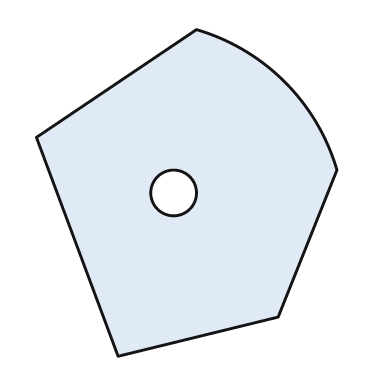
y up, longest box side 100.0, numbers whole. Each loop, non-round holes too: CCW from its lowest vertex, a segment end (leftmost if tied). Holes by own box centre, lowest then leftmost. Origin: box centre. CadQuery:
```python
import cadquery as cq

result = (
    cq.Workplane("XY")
    .moveTo(-21.0, -50.0)
    .lineTo(28.0, -38.0)
    .lineTo(46.0, 7.0)
    .threePointArc((30.0, 34.0), (3.0, 50.0))
    .lineTo(-46.0, 17.0)
    .close()
    .moveTo(-4.0, 0.0)
    .circle(7.0)
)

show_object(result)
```